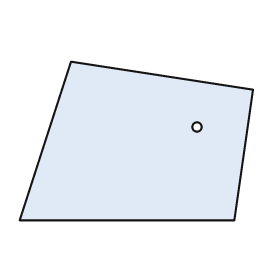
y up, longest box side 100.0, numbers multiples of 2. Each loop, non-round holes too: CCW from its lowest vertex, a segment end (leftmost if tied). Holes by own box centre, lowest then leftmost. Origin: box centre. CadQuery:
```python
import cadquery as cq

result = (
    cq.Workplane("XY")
    .moveTo(-50.0, -34.0)
    .lineTo(42.0, -34.0)
    .lineTo(50.0, 22.0)
    .lineTo(-28.0, 34.0)
    .close()
    .moveTo(26.0, 6.0)
    .circle(2.0)
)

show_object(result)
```